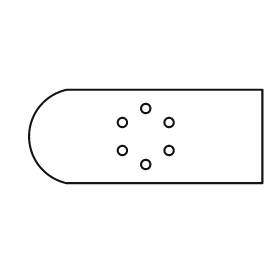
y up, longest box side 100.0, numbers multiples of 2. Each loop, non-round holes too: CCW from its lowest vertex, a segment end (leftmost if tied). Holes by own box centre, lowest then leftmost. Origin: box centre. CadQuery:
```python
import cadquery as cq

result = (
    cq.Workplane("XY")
    .moveTo(-34.0, -20.0)
    .lineTo(50.0, -20.0)
    .lineTo(50.0, 20.0)
    .lineTo(-34.0, 20.0)
    .threePointArc((-50.0, 0.0), (-34.0, -20.0))
    .close()
    .moveTo(0.0, -12.0)
    .circle(2.0)
    .moveTo(-10.0, -6.0)
    .circle(2.0)
    .moveTo(10.0, -6.0)
    .circle(2.0)
    .moveTo(-10.0, 6.0)
    .circle(2.0)
    .moveTo(10.0, 6.0)
    .circle(2.0)
    .moveTo(0.0, 12.0)
    .circle(2.0)
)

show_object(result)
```